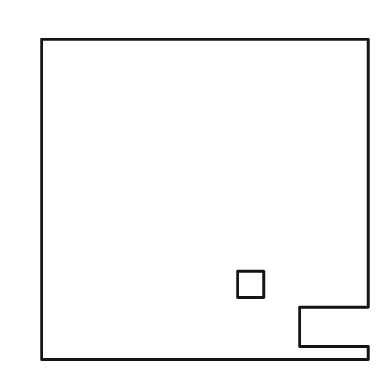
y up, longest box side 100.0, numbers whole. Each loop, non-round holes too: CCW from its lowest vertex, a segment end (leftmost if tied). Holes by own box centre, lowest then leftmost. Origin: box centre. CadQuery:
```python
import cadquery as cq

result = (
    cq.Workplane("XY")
    .moveTo(-50.0, -49.0)
    .lineTo(50.0, -49.0)
    .lineTo(50.0, -45.0)
    .lineTo(29.0, -45.0)
    .lineTo(29.0, -33.0)
    .lineTo(50.0, -33.0)
    .lineTo(50.0, 49.0)
    .lineTo(-50.0, 49.0)
    .close()
    .moveTo(10.0, -30.0)
    .lineTo(18.0, -30.0)
    .lineTo(18.0, -22.0)
    .lineTo(10.0, -22.0)
    .close()
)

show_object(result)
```